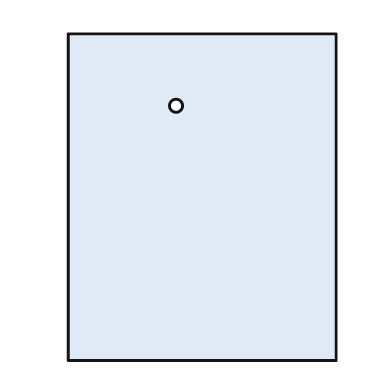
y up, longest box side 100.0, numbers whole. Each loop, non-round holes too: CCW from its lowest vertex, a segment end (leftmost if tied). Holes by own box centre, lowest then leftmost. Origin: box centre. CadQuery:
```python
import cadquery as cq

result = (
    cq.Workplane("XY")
    .moveTo(-41.0, -50.0)
    .lineTo(41.0, -50.0)
    .lineTo(41.0, 50.0)
    .lineTo(-41.0, 50.0)
    .close()
    .moveTo(-8.0, 28.0)
    .circle(2.0)
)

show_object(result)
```